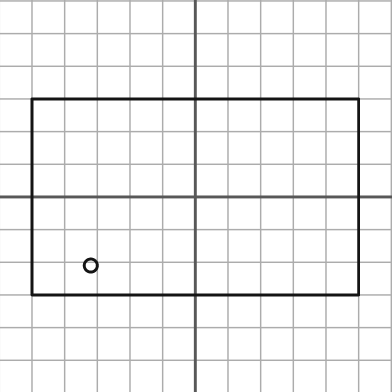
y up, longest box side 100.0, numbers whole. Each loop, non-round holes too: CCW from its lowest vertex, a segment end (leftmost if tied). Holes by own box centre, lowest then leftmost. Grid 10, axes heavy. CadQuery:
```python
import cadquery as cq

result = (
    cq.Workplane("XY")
    .moveTo(-50.0, -30.0)
    .lineTo(50.0, -30.0)
    .lineTo(50.0, 30.0)
    .lineTo(-50.0, 30.0)
    .close()
    .moveTo(-32.0, -21.0)
    .circle(2.0)
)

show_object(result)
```